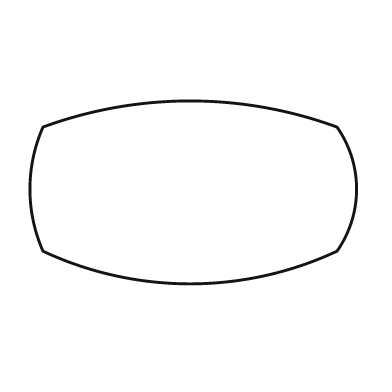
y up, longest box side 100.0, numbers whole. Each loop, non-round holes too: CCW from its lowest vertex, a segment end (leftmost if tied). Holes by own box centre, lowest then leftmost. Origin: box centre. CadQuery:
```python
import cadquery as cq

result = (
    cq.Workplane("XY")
    .moveTo(-46.0, -18.0)
    .threePointArc((-1.0, -28.0), (44.0, -18.0))
    .threePointArc((50.0, 1.0), (44.0, 20.0))
    .threePointArc((-1.0, 28.0), (-46.0, 20.0))
    .threePointArc((-50.0, 1.0), (-46.0, -18.0))
    .close()
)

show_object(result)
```